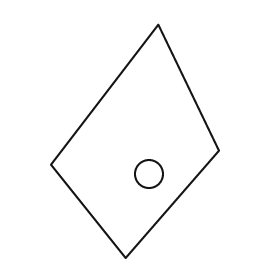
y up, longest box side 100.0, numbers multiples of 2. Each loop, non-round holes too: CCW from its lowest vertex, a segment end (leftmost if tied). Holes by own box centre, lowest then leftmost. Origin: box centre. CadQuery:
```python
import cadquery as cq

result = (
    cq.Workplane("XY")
    .moveTo(-4.0, -50.0)
    .lineTo(36.0, -4.0)
    .lineTo(10.0, 50.0)
    .lineTo(-36.0, -10.0)
    .close()
    .moveTo(6.0, -14.0)
    .circle(6.0)
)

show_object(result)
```